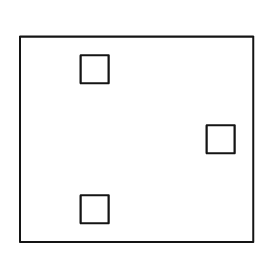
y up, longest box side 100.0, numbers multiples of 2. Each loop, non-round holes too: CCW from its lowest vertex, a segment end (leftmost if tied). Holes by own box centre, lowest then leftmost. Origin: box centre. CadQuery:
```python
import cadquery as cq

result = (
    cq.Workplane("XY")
    .moveTo(-50.0, -44.0)
    .lineTo(50.0, -44.0)
    .lineTo(50.0, 44.0)
    .lineTo(-50.0, 44.0)
    .close()
    .moveTo(-24.0, -36.0)
    .lineTo(-12.0, -36.0)
    .lineTo(-12.0, -24.0)
    .lineTo(-24.0, -24.0)
    .close()
    .moveTo(30.0, -6.0)
    .lineTo(42.0, -6.0)
    .lineTo(42.0, 6.0)
    .lineTo(30.0, 6.0)
    .close()
    .moveTo(-24.0, 24.0)
    .lineTo(-12.0, 24.0)
    .lineTo(-12.0, 36.0)
    .lineTo(-24.0, 36.0)
    .close()
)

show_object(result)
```